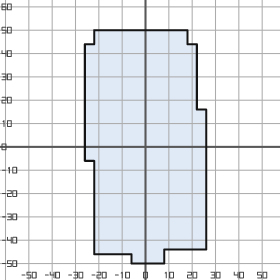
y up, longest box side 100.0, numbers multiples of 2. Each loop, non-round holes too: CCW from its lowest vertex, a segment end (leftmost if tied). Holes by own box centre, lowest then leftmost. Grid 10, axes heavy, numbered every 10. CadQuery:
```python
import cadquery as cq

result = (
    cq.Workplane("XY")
    .moveTo(-6.0, -50.0)
    .lineTo(8.0, -50.0)
    .lineTo(8.0, -44.0)
    .lineTo(26.0, -44.0)
    .lineTo(26.0, 16.0)
    .lineTo(22.0, 16.0)
    .lineTo(22.0, 44.0)
    .lineTo(18.0, 44.0)
    .lineTo(18.0, 50.0)
    .lineTo(-22.0, 50.0)
    .lineTo(-22.0, 44.0)
    .lineTo(-26.0, 44.0)
    .lineTo(-26.0, -6.0)
    .lineTo(-22.0, -6.0)
    .lineTo(-22.0, -46.0)
    .lineTo(-6.0, -46.0)
    .close()
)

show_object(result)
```